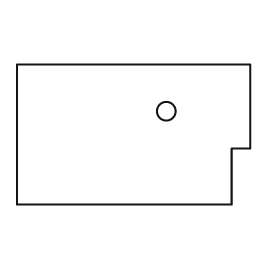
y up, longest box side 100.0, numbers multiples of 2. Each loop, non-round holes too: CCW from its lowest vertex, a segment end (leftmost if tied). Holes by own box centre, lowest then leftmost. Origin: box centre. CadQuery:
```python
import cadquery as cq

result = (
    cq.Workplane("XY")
    .moveTo(-50.0, -30.0)
    .lineTo(42.0, -30.0)
    .lineTo(42.0, -6.0)
    .lineTo(50.0, -6.0)
    .lineTo(50.0, 30.0)
    .lineTo(-50.0, 30.0)
    .close()
    .moveTo(14.0, 10.0)
    .circle(4.0)
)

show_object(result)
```